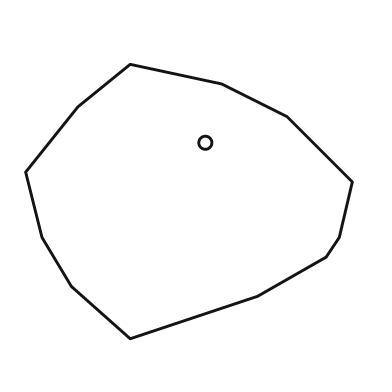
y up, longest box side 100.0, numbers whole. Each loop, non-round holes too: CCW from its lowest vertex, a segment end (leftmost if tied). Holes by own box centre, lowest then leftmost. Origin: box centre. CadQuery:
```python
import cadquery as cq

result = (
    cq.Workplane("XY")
    .moveTo(-18.0, -42.0)
    .lineTo(21.0, -29.0)
    .lineTo(42.0, -17.0)
    .lineTo(46.0, -11.0)
    .lineTo(50.0, 6.0)
    .lineTo(30.0, 26.0)
    .lineTo(10.0, 36.0)
    .lineTo(-18.0, 42.0)
    .lineTo(-34.0, 29.0)
    .lineTo(-50.0, 9.0)
    .lineTo(-45.0, -11.0)
    .lineTo(-36.0, -26.0)
    .close()
    .moveTo(5.0, 18.0)
    .circle(2.0)
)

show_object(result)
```